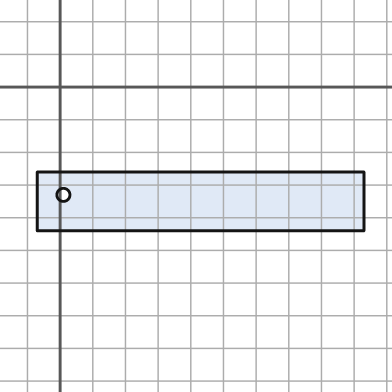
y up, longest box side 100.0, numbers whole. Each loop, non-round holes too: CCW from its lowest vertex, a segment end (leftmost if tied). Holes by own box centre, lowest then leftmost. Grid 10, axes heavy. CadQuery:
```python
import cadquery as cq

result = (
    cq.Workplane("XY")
    .moveTo(-7.0, -44.0)
    .lineTo(93.0, -44.0)
    .lineTo(93.0, -26.0)
    .lineTo(-7.0, -26.0)
    .close()
    .moveTo(1.0, -33.0)
    .circle(2.0)
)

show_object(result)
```